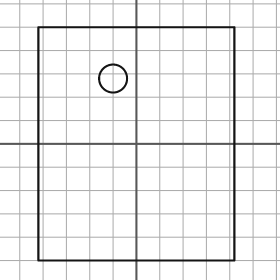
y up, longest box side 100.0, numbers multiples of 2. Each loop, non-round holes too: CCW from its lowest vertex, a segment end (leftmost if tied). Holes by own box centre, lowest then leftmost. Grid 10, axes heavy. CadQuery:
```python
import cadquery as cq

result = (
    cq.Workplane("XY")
    .moveTo(-42.0, -50.0)
    .lineTo(42.0, -50.0)
    .lineTo(42.0, 50.0)
    .lineTo(-42.0, 50.0)
    .close()
    .moveTo(-10.0, 28.0)
    .circle(6.0)
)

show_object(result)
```